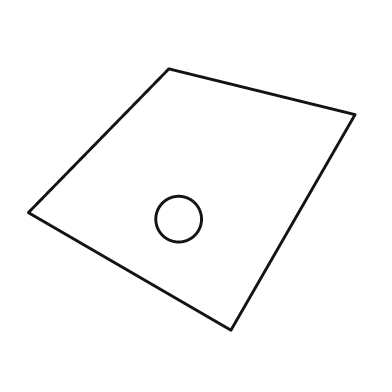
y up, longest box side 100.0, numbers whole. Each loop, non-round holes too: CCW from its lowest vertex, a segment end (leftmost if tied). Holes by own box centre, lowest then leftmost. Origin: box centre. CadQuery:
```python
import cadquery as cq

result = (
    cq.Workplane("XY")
    .moveTo(12.0, -40.0)
    .lineTo(50.0, 26.0)
    .lineTo(-7.0, 40.0)
    .lineTo(-50.0, -4.0)
    .close()
    .moveTo(-4.0, -6.0)
    .circle(7.0)
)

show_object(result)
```